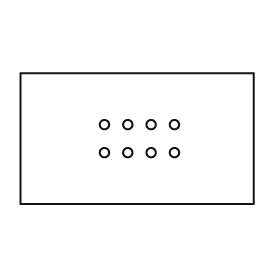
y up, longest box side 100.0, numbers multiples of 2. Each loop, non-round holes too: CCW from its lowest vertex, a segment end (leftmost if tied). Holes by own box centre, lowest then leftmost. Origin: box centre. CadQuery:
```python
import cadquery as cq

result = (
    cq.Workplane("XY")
    .moveTo(-50.0, -28.0)
    .lineTo(50.0, -28.0)
    .lineTo(50.0, 28.0)
    .lineTo(-50.0, 28.0)
    .close()
    .moveTo(-14.0, -6.0)
    .circle(2.0)
    .moveTo(-4.0, -6.0)
    .circle(2.0)
    .moveTo(6.0, -6.0)
    .circle(2.0)
    .moveTo(16.0, -6.0)
    .circle(2.0)
    .moveTo(-14.0, 6.0)
    .circle(2.0)
    .moveTo(-4.0, 6.0)
    .circle(2.0)
    .moveTo(6.0, 6.0)
    .circle(2.0)
    .moveTo(16.0, 6.0)
    .circle(2.0)
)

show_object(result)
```